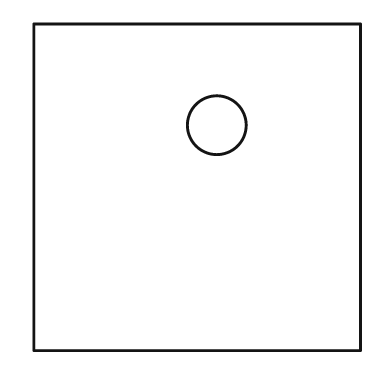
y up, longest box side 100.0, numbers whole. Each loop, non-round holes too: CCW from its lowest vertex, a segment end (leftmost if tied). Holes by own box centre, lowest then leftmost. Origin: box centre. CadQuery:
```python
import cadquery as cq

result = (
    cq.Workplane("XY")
    .moveTo(-50.0, -50.0)
    .lineTo(50.0, -50.0)
    .lineTo(50.0, 50.0)
    .lineTo(-50.0, 50.0)
    .close()
    .moveTo(6.0, 19.0)
    .circle(9.0)
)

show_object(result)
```